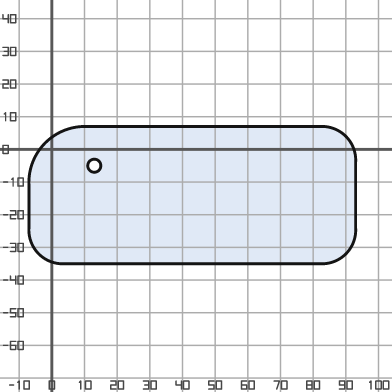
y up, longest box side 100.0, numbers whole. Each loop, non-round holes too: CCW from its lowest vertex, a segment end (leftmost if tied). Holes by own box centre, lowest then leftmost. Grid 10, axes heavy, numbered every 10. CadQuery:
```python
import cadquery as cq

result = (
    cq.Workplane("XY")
    .moveTo(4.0, -35.0)
    .lineTo(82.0, -35.0)
    .threePointArc((90.0, -32.0), (93.0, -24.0))
    .lineTo(93.0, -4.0)
    .threePointArc((90.0, 4.0), (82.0, 7.0))
    .lineTo(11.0, 7.0)
    .threePointArc((-2.0, 2.0), (-7.0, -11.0))
    .lineTo(-7.0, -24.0)
    .threePointArc((-4.0, -32.0), (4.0, -35.0))
    .close()
    .moveTo(13.0, -5.0)
    .circle(2.0)
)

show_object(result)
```